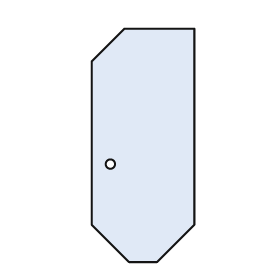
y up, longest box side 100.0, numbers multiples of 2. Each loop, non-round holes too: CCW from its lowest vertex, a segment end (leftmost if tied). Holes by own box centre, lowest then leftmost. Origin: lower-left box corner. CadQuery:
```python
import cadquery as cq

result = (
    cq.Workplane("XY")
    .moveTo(16.0, 0.0)
    .lineTo(28.0, 0.0)
    .lineTo(44.0, 16.0)
    .lineTo(44.0, 100.0)
    .lineTo(14.0, 100.0)
    .lineTo(0.0, 86.0)
    .lineTo(0.0, 16.0)
    .close()
    .moveTo(8.0, 42.0)
    .circle(2.0)
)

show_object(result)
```